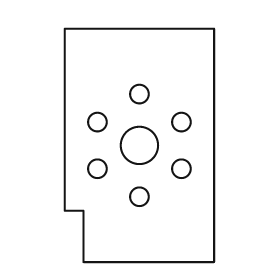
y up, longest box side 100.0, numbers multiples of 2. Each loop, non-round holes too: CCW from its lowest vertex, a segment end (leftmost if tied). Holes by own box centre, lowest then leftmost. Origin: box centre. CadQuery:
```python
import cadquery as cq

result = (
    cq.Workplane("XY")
    .moveTo(-24.0, -50.0)
    .lineTo(32.0, -50.0)
    .lineTo(32.0, 50.0)
    .lineTo(-32.0, 50.0)
    .lineTo(-32.0, -28.0)
    .lineTo(-24.0, -28.0)
    .close()
    .moveTo(0.0, -22.0)
    .circle(4.0)
    .moveTo(-18.0, -10.0)
    .circle(4.0)
    .moveTo(18.0, -10.0)
    .circle(4.0)
    .moveTo(0.0, 0.0)
    .circle(8.0)
    .moveTo(-18.0, 10.0)
    .circle(4.0)
    .moveTo(18.0, 10.0)
    .circle(4.0)
    .moveTo(0.0, 22.0)
    .circle(4.0)
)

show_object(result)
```